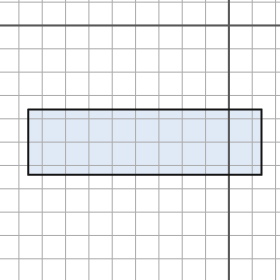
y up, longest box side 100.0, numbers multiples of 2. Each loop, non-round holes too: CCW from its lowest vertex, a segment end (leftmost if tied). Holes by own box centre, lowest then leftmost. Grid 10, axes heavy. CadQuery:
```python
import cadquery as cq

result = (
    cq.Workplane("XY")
    .moveTo(-86.0, -64.0)
    .lineTo(14.0, -64.0)
    .lineTo(14.0, -36.0)
    .lineTo(-86.0, -36.0)
    .close()
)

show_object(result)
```